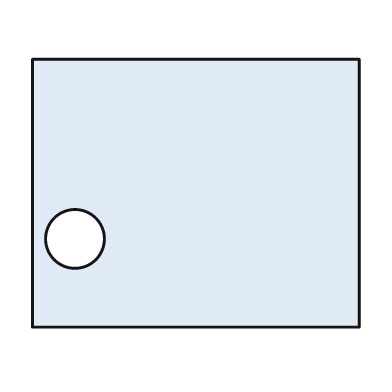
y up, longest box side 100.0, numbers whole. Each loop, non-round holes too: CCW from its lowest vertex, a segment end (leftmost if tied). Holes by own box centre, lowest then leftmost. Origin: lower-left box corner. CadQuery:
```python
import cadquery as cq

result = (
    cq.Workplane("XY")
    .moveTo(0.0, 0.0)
    .lineTo(100.0, 0.0)
    .lineTo(100.0, 82.0)
    .lineTo(0.0, 82.0)
    .close()
    .moveTo(13.0, 27.0)
    .circle(9.0)
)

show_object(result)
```